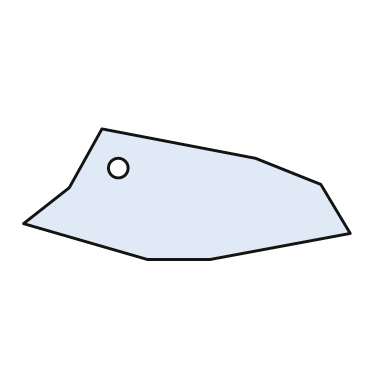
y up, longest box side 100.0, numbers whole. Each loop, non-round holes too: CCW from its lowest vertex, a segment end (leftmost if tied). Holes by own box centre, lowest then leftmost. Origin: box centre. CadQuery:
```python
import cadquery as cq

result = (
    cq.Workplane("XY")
    .moveTo(-12.0, -20.0)
    .lineTo(7.0, -20.0)
    .lineTo(50.0, -12.0)
    .lineTo(41.0, 3.0)
    .lineTo(21.0, 11.0)
    .lineTo(-26.0, 20.0)
    .lineTo(-36.0, 2.0)
    .lineTo(-50.0, -9.0)
    .close()
    .moveTo(-21.0, 8.0)
    .circle(3.0)
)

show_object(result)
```